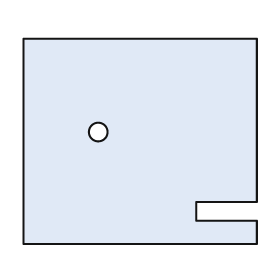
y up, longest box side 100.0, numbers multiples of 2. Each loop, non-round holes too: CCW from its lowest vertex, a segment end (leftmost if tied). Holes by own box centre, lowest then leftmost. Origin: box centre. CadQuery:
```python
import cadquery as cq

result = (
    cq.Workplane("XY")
    .moveTo(-50.0, -44.0)
    .lineTo(50.0, -44.0)
    .lineTo(50.0, -34.0)
    .lineTo(24.0, -34.0)
    .lineTo(24.0, -26.0)
    .lineTo(50.0, -26.0)
    .lineTo(50.0, 44.0)
    .lineTo(-50.0, 44.0)
    .close()
    .moveTo(-18.0, 4.0)
    .circle(4.0)
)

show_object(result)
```